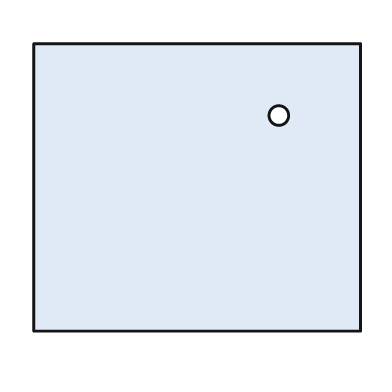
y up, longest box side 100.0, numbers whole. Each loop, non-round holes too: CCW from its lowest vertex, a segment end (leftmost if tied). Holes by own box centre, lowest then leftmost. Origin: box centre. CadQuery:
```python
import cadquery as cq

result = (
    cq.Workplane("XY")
    .moveTo(-50.0, -44.0)
    .lineTo(50.0, -44.0)
    .lineTo(50.0, 44.0)
    .lineTo(-50.0, 44.0)
    .close()
    .moveTo(25.0, 22.0)
    .circle(3.0)
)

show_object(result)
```